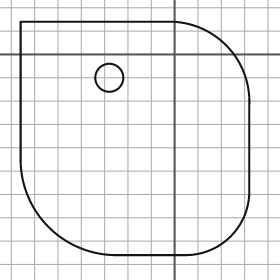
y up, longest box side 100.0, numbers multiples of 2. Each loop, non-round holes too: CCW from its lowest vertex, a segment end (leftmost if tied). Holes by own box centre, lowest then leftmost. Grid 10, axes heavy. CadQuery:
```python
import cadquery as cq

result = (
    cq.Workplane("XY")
    .moveTo(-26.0, -86.0)
    .lineTo(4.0, -86.0)
    .threePointArc((24.0, -78.0), (32.0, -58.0))
    .lineTo(32.0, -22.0)
    .threePointArc((22.0, 4.0), (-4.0, 14.0))
    .lineTo(-66.0, 14.0)
    .lineTo(-66.0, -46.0)
    .threePointArc((-54.0, -74.0), (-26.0, -86.0))
    .close()
    .moveTo(-28.0, -10.0)
    .circle(6.0)
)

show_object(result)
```